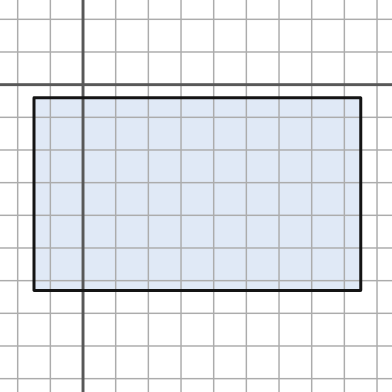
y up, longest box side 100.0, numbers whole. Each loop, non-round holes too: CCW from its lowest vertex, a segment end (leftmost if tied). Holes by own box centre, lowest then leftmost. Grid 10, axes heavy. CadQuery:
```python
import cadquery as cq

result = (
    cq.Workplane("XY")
    .moveTo(-15.0, -63.0)
    .lineTo(85.0, -63.0)
    .lineTo(85.0, -4.0)
    .lineTo(-15.0, -4.0)
    .close()
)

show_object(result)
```